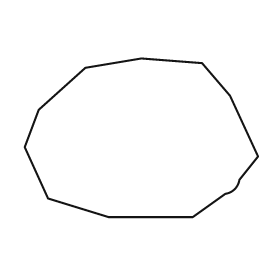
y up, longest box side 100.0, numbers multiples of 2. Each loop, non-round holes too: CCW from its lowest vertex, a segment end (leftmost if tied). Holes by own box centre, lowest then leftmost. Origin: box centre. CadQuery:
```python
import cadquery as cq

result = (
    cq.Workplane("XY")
    .moveTo(-14.0, -34.0)
    .lineTo(22.0, -34.0)
    .lineTo(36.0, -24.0)
    .threePointArc((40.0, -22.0), (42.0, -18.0))
    .lineTo(50.0, -8.0)
    .lineTo(38.0, 18.0)
    .lineTo(26.0, 32.0)
    .lineTo(0.0, 34.0)
    .lineTo(-24.0, 30.0)
    .lineTo(-44.0, 12.0)
    .lineTo(-50.0, -4.0)
    .lineTo(-40.0, -26.0)
    .close()
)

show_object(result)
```